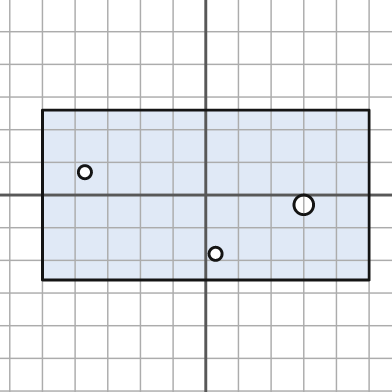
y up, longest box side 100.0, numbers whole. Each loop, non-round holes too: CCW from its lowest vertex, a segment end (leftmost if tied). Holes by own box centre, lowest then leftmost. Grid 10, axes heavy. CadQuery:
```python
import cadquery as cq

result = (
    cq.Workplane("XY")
    .moveTo(-50.0, -26.0)
    .lineTo(50.0, -26.0)
    .lineTo(50.0, 26.0)
    .lineTo(-50.0, 26.0)
    .close()
    .moveTo(3.0, -18.0)
    .circle(2.0)
    .moveTo(30.0, -3.0)
    .circle(3.0)
    .moveTo(-37.0, 7.0)
    .circle(2.0)
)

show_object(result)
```